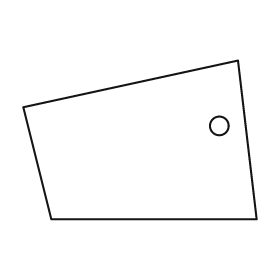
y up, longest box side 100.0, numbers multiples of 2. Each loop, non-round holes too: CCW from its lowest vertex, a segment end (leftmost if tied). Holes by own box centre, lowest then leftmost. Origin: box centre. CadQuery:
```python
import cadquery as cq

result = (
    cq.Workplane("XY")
    .moveTo(-38.0, -34.0)
    .lineTo(50.0, -34.0)
    .lineTo(42.0, 34.0)
    .lineTo(-50.0, 14.0)
    .close()
    .moveTo(34.0, 6.0)
    .circle(4.0)
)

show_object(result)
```